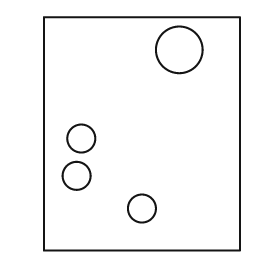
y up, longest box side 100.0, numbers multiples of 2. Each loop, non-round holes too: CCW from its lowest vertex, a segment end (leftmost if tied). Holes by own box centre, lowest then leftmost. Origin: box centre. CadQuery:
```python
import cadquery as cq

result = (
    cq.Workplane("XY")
    .moveTo(-42.0, -50.0)
    .lineTo(42.0, -50.0)
    .lineTo(42.0, 50.0)
    .lineTo(-42.0, 50.0)
    .close()
    .moveTo(0.0, -32.0)
    .circle(6.0)
    .moveTo(-28.0, -18.0)
    .circle(6.0)
    .moveTo(-26.0, -2.0)
    .circle(6.0)
    .moveTo(16.0, 36.0)
    .circle(10.0)
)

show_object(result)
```